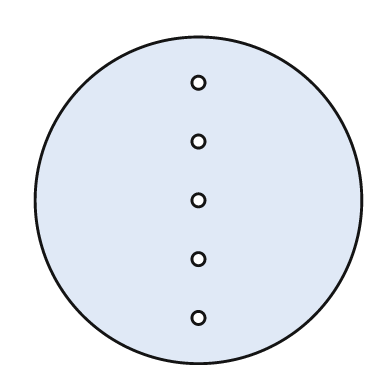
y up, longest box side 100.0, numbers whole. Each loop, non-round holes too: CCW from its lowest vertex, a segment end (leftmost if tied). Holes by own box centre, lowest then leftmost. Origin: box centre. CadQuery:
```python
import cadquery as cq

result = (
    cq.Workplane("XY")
    .moveTo(0.0, 0.0)
    .circle(50.0)
    .moveTo(0.0, -36.0)
    .circle(2.0)
    .moveTo(0.0, -18.0)
    .circle(2.0)
    .moveTo(0.0, 0.0)
    .circle(2.0)
    .moveTo(0.0, 18.0)
    .circle(2.0)
    .moveTo(0.0, 36.0)
    .circle(2.0)
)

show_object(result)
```